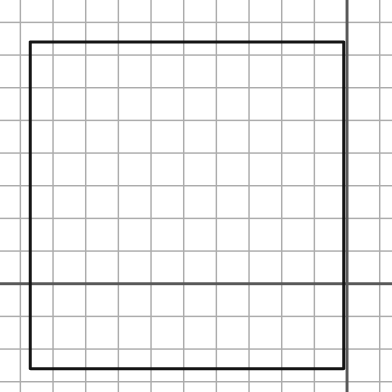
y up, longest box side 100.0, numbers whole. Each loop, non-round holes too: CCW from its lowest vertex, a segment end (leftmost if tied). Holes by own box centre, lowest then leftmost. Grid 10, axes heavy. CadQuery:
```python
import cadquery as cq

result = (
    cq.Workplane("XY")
    .moveTo(-97.0, -26.0)
    .lineTo(-1.0, -26.0)
    .lineTo(-1.0, 74.0)
    .lineTo(-97.0, 74.0)
    .close()
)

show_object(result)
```